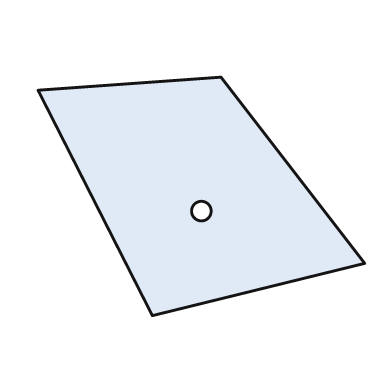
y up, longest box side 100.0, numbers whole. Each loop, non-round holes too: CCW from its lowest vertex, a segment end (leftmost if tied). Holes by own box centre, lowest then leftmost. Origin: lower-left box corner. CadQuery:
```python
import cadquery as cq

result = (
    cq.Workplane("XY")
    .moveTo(35.0, 0.0)
    .lineTo(100.0, 16.0)
    .lineTo(56.0, 73.0)
    .lineTo(0.0, 69.0)
    .close()
    .moveTo(50.0, 32.0)
    .circle(3.0)
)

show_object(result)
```